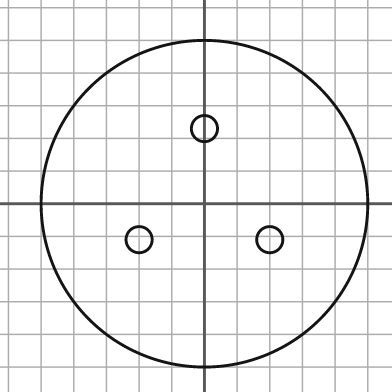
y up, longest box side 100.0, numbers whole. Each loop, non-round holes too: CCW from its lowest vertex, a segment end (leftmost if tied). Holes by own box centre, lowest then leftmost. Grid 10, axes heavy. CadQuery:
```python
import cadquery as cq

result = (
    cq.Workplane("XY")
    .moveTo(0.0, 0.0)
    .circle(50.0)
    .moveTo(-20.0, -11.0)
    .circle(4.0)
    .moveTo(20.0, -11.0)
    .circle(4.0)
    .moveTo(0.0, 23.0)
    .circle(4.0)
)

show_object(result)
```